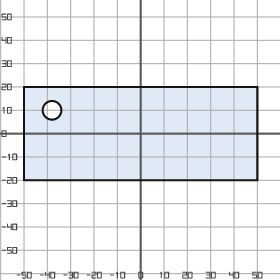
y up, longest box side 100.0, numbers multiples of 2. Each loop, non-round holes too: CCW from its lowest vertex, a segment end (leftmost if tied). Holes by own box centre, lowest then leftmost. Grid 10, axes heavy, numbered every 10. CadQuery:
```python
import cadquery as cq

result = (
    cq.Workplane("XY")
    .moveTo(-50.0, -20.0)
    .lineTo(50.0, -20.0)
    .lineTo(50.0, 20.0)
    .lineTo(-50.0, 20.0)
    .close()
    .moveTo(-38.0, 10.0)
    .circle(4.0)
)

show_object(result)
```